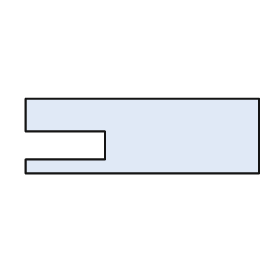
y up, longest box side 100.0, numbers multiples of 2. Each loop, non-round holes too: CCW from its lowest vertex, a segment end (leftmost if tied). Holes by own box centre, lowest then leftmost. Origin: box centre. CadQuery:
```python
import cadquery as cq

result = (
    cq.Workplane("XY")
    .moveTo(-50.0, -16.0)
    .lineTo(50.0, -16.0)
    .lineTo(50.0, 16.0)
    .lineTo(-50.0, 16.0)
    .lineTo(-50.0, 2.0)
    .lineTo(-16.0, 2.0)
    .lineTo(-16.0, -10.0)
    .lineTo(-50.0, -10.0)
    .close()
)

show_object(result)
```